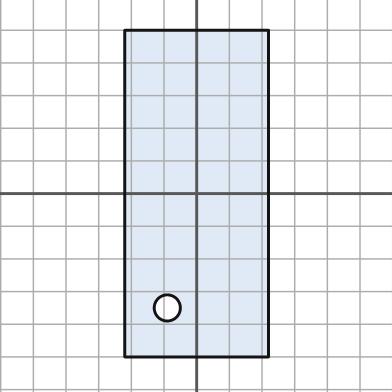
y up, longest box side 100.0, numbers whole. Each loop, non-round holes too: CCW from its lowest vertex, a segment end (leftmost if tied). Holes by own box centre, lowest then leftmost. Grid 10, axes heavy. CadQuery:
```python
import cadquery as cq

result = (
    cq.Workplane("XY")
    .moveTo(-22.0, -50.0)
    .lineTo(22.0, -50.0)
    .lineTo(22.0, 50.0)
    .lineTo(-22.0, 50.0)
    .close()
    .moveTo(-9.0, -35.0)
    .circle(4.0)
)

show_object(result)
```